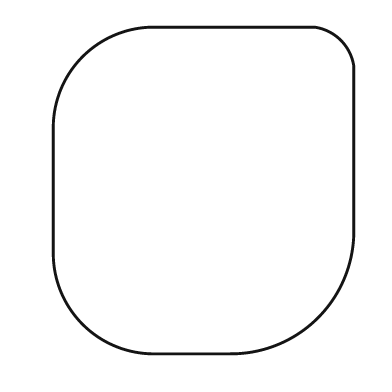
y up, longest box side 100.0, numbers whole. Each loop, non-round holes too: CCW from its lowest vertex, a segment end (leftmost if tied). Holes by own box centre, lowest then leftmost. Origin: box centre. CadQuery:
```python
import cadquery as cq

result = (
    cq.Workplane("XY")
    .moveTo(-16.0, -50.0)
    .lineTo(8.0, -50.0)
    .threePointArc((35.0, -39.0), (46.0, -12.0))
    .lineTo(46.0, 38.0)
    .threePointArc((42.0, 46.0), (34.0, 50.0))
    .lineTo(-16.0, 50.0)
    .threePointArc((-37.0, 41.0), (-46.0, 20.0))
    .lineTo(-46.0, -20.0)
    .threePointArc((-37.0, -41.0), (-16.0, -50.0))
    .close()
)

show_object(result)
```